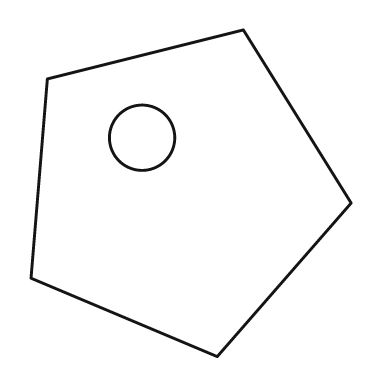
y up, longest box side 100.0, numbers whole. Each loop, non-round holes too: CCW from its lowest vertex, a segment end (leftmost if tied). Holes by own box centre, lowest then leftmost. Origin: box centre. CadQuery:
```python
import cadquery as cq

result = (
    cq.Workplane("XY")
    .moveTo(8.0, -50.0)
    .lineTo(49.0, -3.0)
    .lineTo(16.0, 50.0)
    .lineTo(-44.0, 35.0)
    .lineTo(-49.0, -26.0)
    .close()
    .moveTo(-15.0, 17.0)
    .circle(10.0)
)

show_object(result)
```